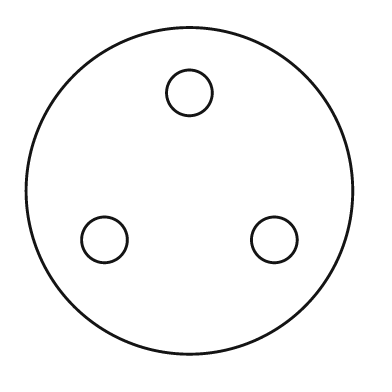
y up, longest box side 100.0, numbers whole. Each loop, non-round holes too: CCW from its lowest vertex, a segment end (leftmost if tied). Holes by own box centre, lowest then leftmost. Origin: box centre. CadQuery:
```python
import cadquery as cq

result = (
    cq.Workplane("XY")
    .moveTo(0.0, 0.0)
    .circle(50.0)
    .moveTo(-26.0, -15.0)
    .circle(7.0)
    .moveTo(26.0, -15.0)
    .circle(7.0)
    .moveTo(0.0, 30.0)
    .circle(7.0)
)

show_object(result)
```